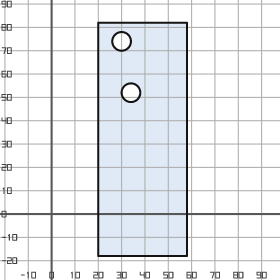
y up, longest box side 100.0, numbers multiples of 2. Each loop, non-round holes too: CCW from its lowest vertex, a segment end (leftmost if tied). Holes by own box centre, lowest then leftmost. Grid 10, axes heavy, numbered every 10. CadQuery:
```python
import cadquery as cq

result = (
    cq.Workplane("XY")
    .moveTo(20.0, -18.0)
    .lineTo(58.0, -18.0)
    .lineTo(58.0, 82.0)
    .lineTo(20.0, 82.0)
    .close()
    .moveTo(34.0, 52.0)
    .circle(4.0)
    .moveTo(30.0, 74.0)
    .circle(4.0)
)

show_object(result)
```